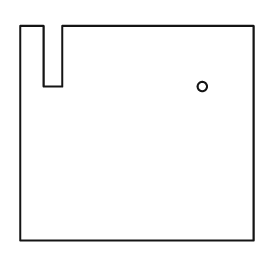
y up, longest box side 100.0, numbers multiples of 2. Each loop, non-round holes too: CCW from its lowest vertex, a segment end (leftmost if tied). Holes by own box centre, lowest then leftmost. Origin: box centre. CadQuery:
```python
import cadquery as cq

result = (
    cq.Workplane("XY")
    .moveTo(-50.0, -46.0)
    .lineTo(50.0, -46.0)
    .lineTo(50.0, 46.0)
    .lineTo(-32.0, 46.0)
    .lineTo(-32.0, 20.0)
    .lineTo(-40.0, 20.0)
    .lineTo(-40.0, 46.0)
    .lineTo(-50.0, 46.0)
    .close()
    .moveTo(28.0, 20.0)
    .circle(2.0)
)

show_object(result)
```